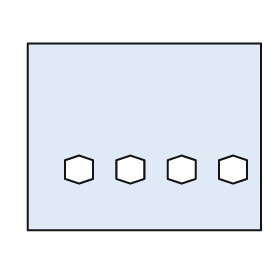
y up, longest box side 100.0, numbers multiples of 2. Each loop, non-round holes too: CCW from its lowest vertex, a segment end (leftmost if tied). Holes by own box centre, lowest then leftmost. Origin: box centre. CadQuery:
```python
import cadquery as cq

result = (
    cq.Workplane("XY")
    .moveTo(-50.0, -40.0)
    .lineTo(50.0, -40.0)
    .lineTo(50.0, 40.0)
    .lineTo(-50.0, 40.0)
    .close()
    .moveTo(-28.0, -20.0)
    .lineTo(-22.0, -18.0)
    .lineTo(-22.0, -10.0)
    .lineTo(-28.0, -8.0)
    .lineTo(-34.0, -10.0)
    .lineTo(-34.0, -18.0)
    .close()
    .moveTo(-6.0, -20.0)
    .lineTo(0.0, -18.0)
    .lineTo(0.0, -10.0)
    .lineTo(-6.0, -8.0)
    .lineTo(-12.0, -10.0)
    .lineTo(-12.0, -18.0)
    .close()
    .moveTo(16.0, -20.0)
    .lineTo(22.0, -18.0)
    .lineTo(22.0, -10.0)
    .lineTo(16.0, -8.0)
    .lineTo(10.0, -10.0)
    .lineTo(10.0, -18.0)
    .close()
    .moveTo(38.0, -20.0)
    .lineTo(44.0, -18.0)
    .lineTo(44.0, -10.0)
    .lineTo(38.0, -8.0)
    .lineTo(32.0, -10.0)
    .lineTo(32.0, -18.0)
    .close()
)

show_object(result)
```